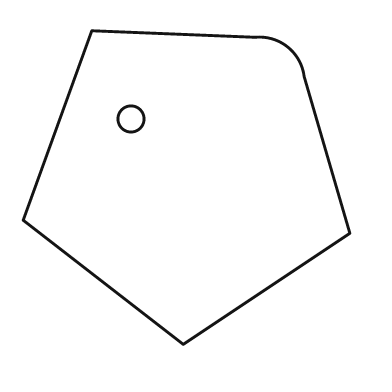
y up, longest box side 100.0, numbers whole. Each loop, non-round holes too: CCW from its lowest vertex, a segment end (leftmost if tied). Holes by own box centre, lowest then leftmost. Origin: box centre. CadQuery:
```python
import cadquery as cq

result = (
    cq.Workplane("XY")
    .moveTo(-1.0, -48.0)
    .lineTo(50.0, -14.0)
    .lineTo(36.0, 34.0)
    .threePointArc((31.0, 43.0), (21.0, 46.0))
    .lineTo(-29.0, 48.0)
    .lineTo(-50.0, -10.0)
    .close()
    .moveTo(-17.0, 21.0)
    .circle(4.0)
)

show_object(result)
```